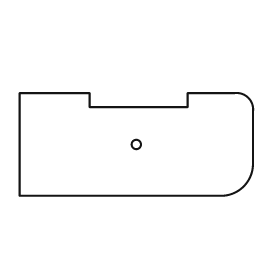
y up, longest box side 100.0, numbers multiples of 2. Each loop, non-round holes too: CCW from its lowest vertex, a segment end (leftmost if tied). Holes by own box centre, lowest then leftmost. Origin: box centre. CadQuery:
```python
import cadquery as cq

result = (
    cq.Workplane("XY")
    .moveTo(-50.0, -22.0)
    .lineTo(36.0, -22.0)
    .threePointArc((46.0, -18.0), (50.0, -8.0))
    .lineTo(50.0, 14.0)
    .threePointArc((48.0, 20.0), (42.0, 22.0))
    .lineTo(22.0, 22.0)
    .lineTo(22.0, 16.0)
    .lineTo(-20.0, 16.0)
    .lineTo(-20.0, 22.0)
    .lineTo(-50.0, 22.0)
    .close()
    .moveTo(0.0, 0.0)
    .circle(2.0)
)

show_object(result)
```